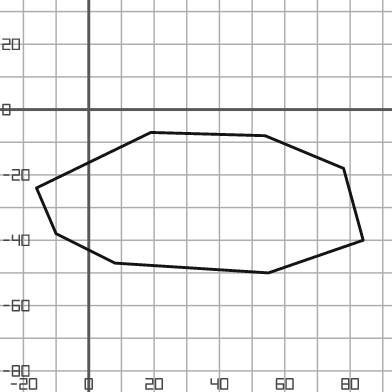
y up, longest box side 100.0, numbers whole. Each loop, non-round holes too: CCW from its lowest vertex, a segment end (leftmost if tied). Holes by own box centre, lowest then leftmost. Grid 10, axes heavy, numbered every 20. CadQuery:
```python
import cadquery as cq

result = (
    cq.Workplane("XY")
    .moveTo(55.0, -50.0)
    .lineTo(84.0, -40.0)
    .lineTo(78.0, -18.0)
    .lineTo(54.0, -8.0)
    .lineTo(19.0, -7.0)
    .lineTo(-16.0, -24.0)
    .lineTo(-10.0, -38.0)
    .lineTo(8.0, -47.0)
    .close()
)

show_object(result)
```